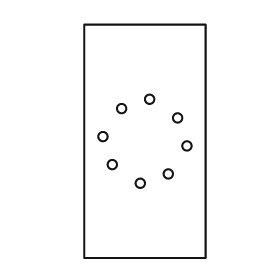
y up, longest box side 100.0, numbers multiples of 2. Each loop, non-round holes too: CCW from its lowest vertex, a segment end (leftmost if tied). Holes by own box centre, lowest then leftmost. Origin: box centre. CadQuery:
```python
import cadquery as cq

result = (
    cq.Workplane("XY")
    .moveTo(-26.0, -50.0)
    .lineTo(26.0, -50.0)
    .lineTo(26.0, 50.0)
    .lineTo(-26.0, 50.0)
    .close()
    .moveTo(-2.0, -18.0)
    .circle(2.0)
    .moveTo(10.0, -14.0)
    .circle(2.0)
    .moveTo(-14.0, -10.0)
    .circle(2.0)
    .moveTo(18.0, -2.0)
    .circle(2.0)
    .moveTo(-18.0, 2.0)
    .circle(2.0)
    .moveTo(14.0, 10.0)
    .circle(2.0)
    .moveTo(-10.0, 14.0)
    .circle(2.0)
    .moveTo(2.0, 18.0)
    .circle(2.0)
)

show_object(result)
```